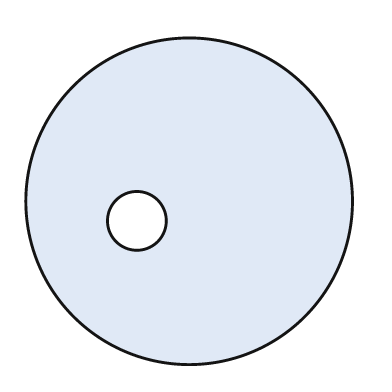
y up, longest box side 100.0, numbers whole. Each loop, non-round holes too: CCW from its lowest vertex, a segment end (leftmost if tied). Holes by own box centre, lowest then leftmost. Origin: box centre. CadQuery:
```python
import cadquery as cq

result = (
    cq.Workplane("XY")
    .moveTo(0.0, 0.0)
    .circle(50.0)
    .moveTo(-16.0, -6.0)
    .circle(9.0)
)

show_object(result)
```